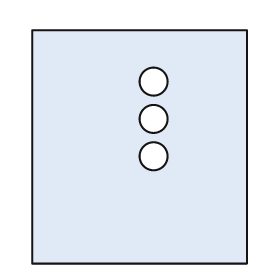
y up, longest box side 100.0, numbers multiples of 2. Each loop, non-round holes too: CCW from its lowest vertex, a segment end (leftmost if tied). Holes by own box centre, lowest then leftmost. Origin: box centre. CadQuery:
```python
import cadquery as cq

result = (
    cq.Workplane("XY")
    .moveTo(-46.0, -50.0)
    .lineTo(46.0, -50.0)
    .lineTo(46.0, 50.0)
    .lineTo(-46.0, 50.0)
    .close()
    .moveTo(6.0, -4.0)
    .circle(6.0)
    .moveTo(6.0, 12.0)
    .circle(6.0)
    .moveTo(6.0, 28.0)
    .circle(6.0)
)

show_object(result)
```